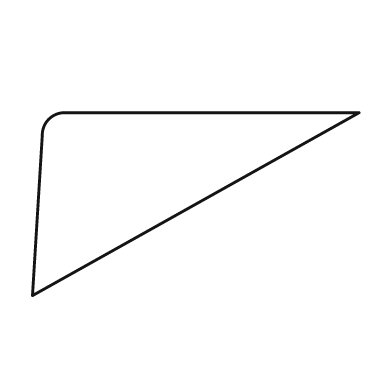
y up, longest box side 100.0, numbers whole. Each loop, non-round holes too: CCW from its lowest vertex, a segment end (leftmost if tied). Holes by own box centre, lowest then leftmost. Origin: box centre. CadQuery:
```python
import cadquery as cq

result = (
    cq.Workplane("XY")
    .moveTo(-50.0, -28.0)
    .lineTo(50.0, 28.0)
    .lineTo(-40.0, 28.0)
    .threePointArc((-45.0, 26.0), (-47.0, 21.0))
    .close()
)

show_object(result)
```